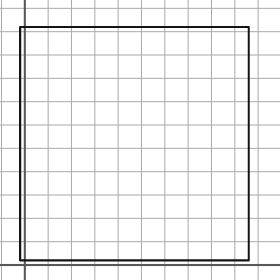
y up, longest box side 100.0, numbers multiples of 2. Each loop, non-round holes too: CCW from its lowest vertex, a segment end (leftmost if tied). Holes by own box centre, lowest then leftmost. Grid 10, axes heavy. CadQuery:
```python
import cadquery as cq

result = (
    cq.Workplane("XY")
    .moveTo(-2.0, 2.0)
    .lineTo(96.0, 2.0)
    .lineTo(96.0, 102.0)
    .lineTo(-2.0, 102.0)
    .close()
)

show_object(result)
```